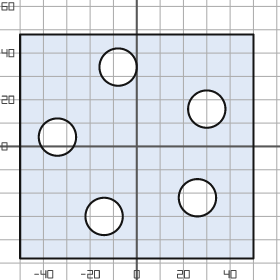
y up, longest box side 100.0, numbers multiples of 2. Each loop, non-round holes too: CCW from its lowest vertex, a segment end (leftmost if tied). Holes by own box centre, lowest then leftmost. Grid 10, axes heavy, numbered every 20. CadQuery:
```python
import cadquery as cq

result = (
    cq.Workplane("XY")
    .moveTo(-50.0, -48.0)
    .lineTo(50.0, -48.0)
    .lineTo(50.0, 48.0)
    .lineTo(-50.0, 48.0)
    .close()
    .moveTo(-14.0, -30.0)
    .circle(8.0)
    .moveTo(26.0, -22.0)
    .circle(8.0)
    .moveTo(-34.0, 4.0)
    .circle(8.0)
    .moveTo(30.0, 16.0)
    .circle(8.0)
    .moveTo(-8.0, 34.0)
    .circle(8.0)
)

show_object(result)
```